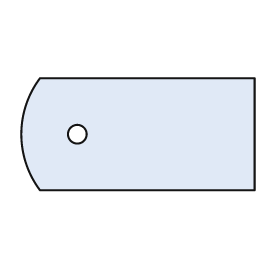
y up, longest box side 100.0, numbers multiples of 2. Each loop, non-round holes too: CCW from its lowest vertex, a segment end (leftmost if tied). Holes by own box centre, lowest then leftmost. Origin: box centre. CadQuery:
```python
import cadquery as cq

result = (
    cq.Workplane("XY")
    .moveTo(-42.0, -24.0)
    .lineTo(50.0, -24.0)
    .lineTo(50.0, 24.0)
    .lineTo(-42.0, 24.0)
    .threePointArc((-50.0, 0.0), (-42.0, -24.0))
    .close()
    .moveTo(-26.0, 0.0)
    .circle(4.0)
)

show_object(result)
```